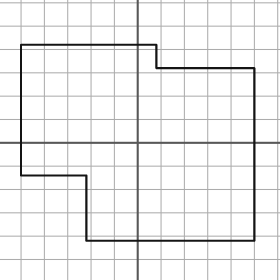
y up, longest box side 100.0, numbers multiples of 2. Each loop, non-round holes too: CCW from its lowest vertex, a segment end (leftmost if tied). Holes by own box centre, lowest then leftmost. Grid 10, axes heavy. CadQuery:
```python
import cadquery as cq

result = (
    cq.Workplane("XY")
    .moveTo(-22.0, -42.0)
    .lineTo(50.0, -42.0)
    .lineTo(50.0, 32.0)
    .lineTo(8.0, 32.0)
    .lineTo(8.0, 42.0)
    .lineTo(-50.0, 42.0)
    .lineTo(-50.0, -14.0)
    .lineTo(-22.0, -14.0)
    .close()
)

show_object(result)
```